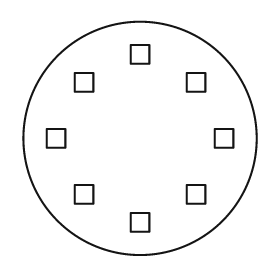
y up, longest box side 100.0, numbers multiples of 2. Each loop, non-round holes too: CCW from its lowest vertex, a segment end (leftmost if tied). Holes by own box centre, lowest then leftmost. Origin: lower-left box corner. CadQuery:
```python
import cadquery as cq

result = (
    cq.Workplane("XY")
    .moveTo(50.0, 50.0)
    .circle(50.0)
    .moveTo(46.0, 10.0)
    .lineTo(54.0, 10.0)
    .lineTo(54.0, 18.0)
    .lineTo(46.0, 18.0)
    .close()
    .moveTo(22.0, 22.0)
    .lineTo(30.0, 22.0)
    .lineTo(30.0, 30.0)
    .lineTo(22.0, 30.0)
    .close()
    .moveTo(70.0, 22.0)
    .lineTo(78.0, 22.0)
    .lineTo(78.0, 30.0)
    .lineTo(70.0, 30.0)
    .close()
    .moveTo(10.0, 46.0)
    .lineTo(18.0, 46.0)
    .lineTo(18.0, 54.0)
    .lineTo(10.0, 54.0)
    .close()
    .moveTo(82.0, 46.0)
    .lineTo(90.0, 46.0)
    .lineTo(90.0, 54.0)
    .lineTo(82.0, 54.0)
    .close()
    .moveTo(22.0, 70.0)
    .lineTo(30.0, 70.0)
    .lineTo(30.0, 78.0)
    .lineTo(22.0, 78.0)
    .close()
    .moveTo(70.0, 70.0)
    .lineTo(78.0, 70.0)
    .lineTo(78.0, 78.0)
    .lineTo(70.0, 78.0)
    .close()
    .moveTo(46.0, 82.0)
    .lineTo(54.0, 82.0)
    .lineTo(54.0, 90.0)
    .lineTo(46.0, 90.0)
    .close()
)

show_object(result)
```